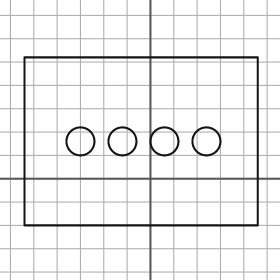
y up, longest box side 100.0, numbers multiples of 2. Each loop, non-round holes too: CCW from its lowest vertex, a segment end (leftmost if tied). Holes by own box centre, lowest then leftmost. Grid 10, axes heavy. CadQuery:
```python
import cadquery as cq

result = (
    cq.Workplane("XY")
    .moveTo(-54.0, -20.0)
    .lineTo(46.0, -20.0)
    .lineTo(46.0, 52.0)
    .lineTo(-54.0, 52.0)
    .close()
    .moveTo(-30.0, 16.0)
    .circle(6.0)
    .moveTo(-12.0, 16.0)
    .circle(6.0)
    .moveTo(6.0, 16.0)
    .circle(6.0)
    .moveTo(24.0, 16.0)
    .circle(6.0)
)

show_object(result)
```